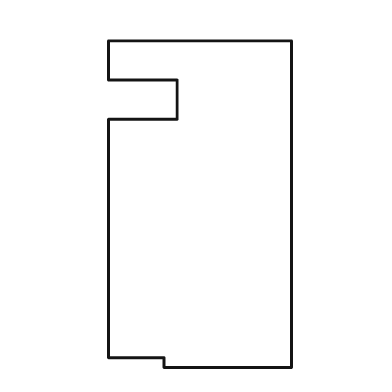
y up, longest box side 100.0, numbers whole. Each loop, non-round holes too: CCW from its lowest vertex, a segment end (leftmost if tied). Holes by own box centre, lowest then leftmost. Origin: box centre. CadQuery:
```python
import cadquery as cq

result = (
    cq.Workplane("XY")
    .moveTo(-11.0, -50.0)
    .lineTo(28.0, -50.0)
    .lineTo(28.0, 50.0)
    .lineTo(-28.0, 50.0)
    .lineTo(-28.0, 38.0)
    .lineTo(-7.0, 38.0)
    .lineTo(-7.0, 26.0)
    .lineTo(-28.0, 26.0)
    .lineTo(-28.0, -47.0)
    .lineTo(-11.0, -47.0)
    .close()
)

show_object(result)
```